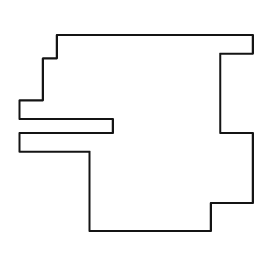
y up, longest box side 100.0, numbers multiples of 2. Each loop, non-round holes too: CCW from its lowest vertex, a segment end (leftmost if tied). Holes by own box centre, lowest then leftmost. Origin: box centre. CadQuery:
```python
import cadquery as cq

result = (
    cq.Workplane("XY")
    .moveTo(-20.0, -42.0)
    .lineTo(32.0, -42.0)
    .lineTo(32.0, -30.0)
    .lineTo(50.0, -30.0)
    .lineTo(50.0, 0.0)
    .lineTo(36.0, 0.0)
    .lineTo(36.0, 34.0)
    .lineTo(50.0, 34.0)
    .lineTo(50.0, 42.0)
    .lineTo(-34.0, 42.0)
    .lineTo(-34.0, 32.0)
    .lineTo(-40.0, 32.0)
    .lineTo(-40.0, 14.0)
    .lineTo(-50.0, 14.0)
    .lineTo(-50.0, 6.0)
    .lineTo(-10.0, 6.0)
    .lineTo(-10.0, 0.0)
    .lineTo(-50.0, 0.0)
    .lineTo(-50.0, -8.0)
    .lineTo(-20.0, -8.0)
    .close()
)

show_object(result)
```